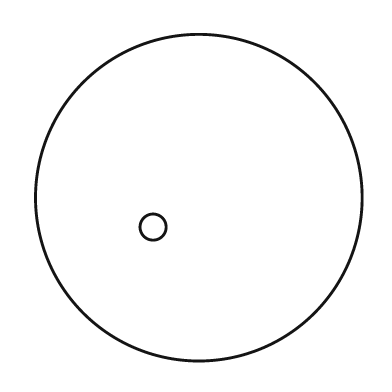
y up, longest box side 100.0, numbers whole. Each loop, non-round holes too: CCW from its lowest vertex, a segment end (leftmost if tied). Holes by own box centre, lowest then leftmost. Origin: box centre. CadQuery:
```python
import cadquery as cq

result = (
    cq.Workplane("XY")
    .moveTo(0.0, 0.0)
    .circle(50.0)
    .moveTo(-14.0, -9.0)
    .circle(4.0)
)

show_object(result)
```